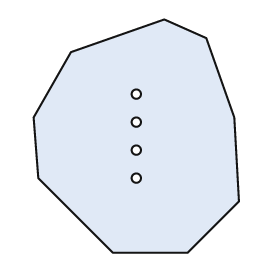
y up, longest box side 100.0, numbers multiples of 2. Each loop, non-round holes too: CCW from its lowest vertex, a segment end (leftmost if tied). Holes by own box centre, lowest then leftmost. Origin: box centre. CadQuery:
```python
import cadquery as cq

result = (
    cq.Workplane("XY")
    .moveTo(-10.0, -50.0)
    .lineTo(22.0, -50.0)
    .lineTo(44.0, -28.0)
    .lineTo(42.0, 8.0)
    .lineTo(30.0, 42.0)
    .lineTo(12.0, 50.0)
    .lineTo(-28.0, 36.0)
    .lineTo(-44.0, 8.0)
    .lineTo(-42.0, -18.0)
    .close()
    .moveTo(0.0, -18.0)
    .circle(2.0)
    .moveTo(0.0, -6.0)
    .circle(2.0)
    .moveTo(0.0, 6.0)
    .circle(2.0)
    .moveTo(0.0, 18.0)
    .circle(2.0)
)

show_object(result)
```